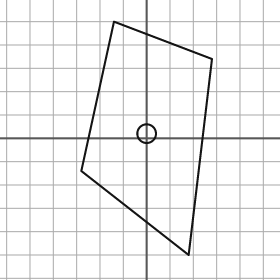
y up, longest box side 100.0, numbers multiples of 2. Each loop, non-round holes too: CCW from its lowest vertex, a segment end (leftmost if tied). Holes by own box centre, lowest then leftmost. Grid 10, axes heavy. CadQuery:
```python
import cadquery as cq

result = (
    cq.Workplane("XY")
    .moveTo(18.0, -50.0)
    .lineTo(28.0, 34.0)
    .lineTo(-14.0, 50.0)
    .lineTo(-28.0, -14.0)
    .close()
    .moveTo(0.0, 2.0)
    .circle(4.0)
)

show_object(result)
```